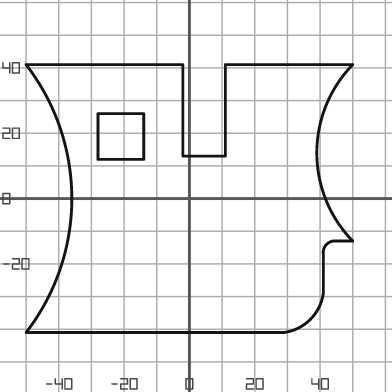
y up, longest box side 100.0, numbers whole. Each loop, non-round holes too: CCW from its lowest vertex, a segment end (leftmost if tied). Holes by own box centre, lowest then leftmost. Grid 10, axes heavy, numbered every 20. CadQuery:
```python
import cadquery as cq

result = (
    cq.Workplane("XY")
    .moveTo(-50.0, -41.0)
    .lineTo(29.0, -41.0)
    .threePointArc((37.0, -37.0), (41.0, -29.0))
    .lineTo(41.0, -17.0)
    .threePointArc((42.0, -14.0), (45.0, -13.0))
    .lineTo(50.0, -13.0)
    .threePointArc((39.0, 14.0), (50.0, 41.0))
    .lineTo(11.0, 41.0)
    .lineTo(11.0, 13.0)
    .lineTo(-2.0, 13.0)
    .lineTo(-2.0, 41.0)
    .lineTo(-50.0, 41.0)
    .threePointArc((-36.0, 0.0), (-50.0, -41.0))
    .close()
    .moveTo(-28.0, 12.0)
    .lineTo(-14.0, 12.0)
    .lineTo(-14.0, 26.0)
    .lineTo(-28.0, 26.0)
    .close()
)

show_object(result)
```